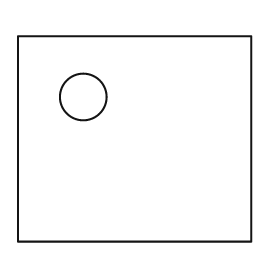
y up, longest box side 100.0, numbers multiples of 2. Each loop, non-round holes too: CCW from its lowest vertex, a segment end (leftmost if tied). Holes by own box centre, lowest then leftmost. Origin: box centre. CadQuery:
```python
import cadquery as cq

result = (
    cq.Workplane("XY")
    .moveTo(-50.0, -44.0)
    .lineTo(50.0, -44.0)
    .lineTo(50.0, 44.0)
    .lineTo(-50.0, 44.0)
    .close()
    .moveTo(-22.0, 18.0)
    .circle(10.0)
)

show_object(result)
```